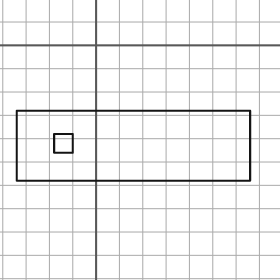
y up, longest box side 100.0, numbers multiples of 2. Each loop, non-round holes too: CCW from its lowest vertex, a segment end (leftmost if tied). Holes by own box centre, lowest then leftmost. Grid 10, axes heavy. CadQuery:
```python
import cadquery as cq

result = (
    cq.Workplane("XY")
    .moveTo(-34.0, -58.0)
    .lineTo(66.0, -58.0)
    .lineTo(66.0, -28.0)
    .lineTo(-34.0, -28.0)
    .close()
    .moveTo(-18.0, -46.0)
    .lineTo(-10.0, -46.0)
    .lineTo(-10.0, -38.0)
    .lineTo(-18.0, -38.0)
    .close()
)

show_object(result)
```